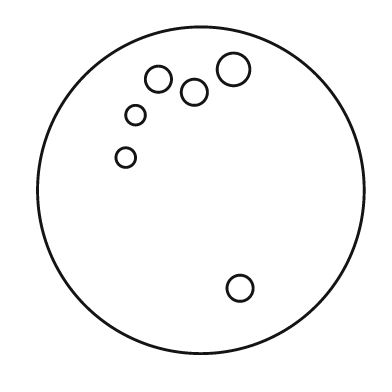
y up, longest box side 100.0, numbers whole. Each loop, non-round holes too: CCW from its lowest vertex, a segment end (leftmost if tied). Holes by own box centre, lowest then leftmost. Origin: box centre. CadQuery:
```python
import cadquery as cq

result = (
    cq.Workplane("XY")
    .moveTo(0.0, 0.0)
    .circle(50.0)
    .moveTo(12.0, -30.0)
    .circle(4.0)
    .moveTo(-23.0, 10.0)
    .circle(3.0)
    .moveTo(-20.0, 23.0)
    .circle(3.0)
    .moveTo(-2.0, 30.0)
    .circle(4.0)
    .moveTo(-13.0, 34.0)
    .circle(4.0)
    .moveTo(10.0, 37.0)
    .circle(5.0)
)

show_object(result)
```